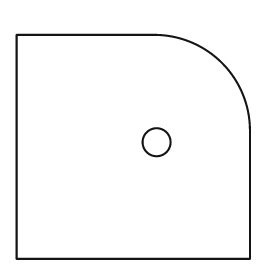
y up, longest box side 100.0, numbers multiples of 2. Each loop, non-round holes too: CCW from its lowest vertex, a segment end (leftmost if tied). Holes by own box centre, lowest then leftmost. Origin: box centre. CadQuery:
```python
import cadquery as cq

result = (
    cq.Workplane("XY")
    .moveTo(-50.0, -48.0)
    .lineTo(50.0, -48.0)
    .lineTo(50.0, 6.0)
    .threePointArc((38.0, 36.0), (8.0, 48.0))
    .lineTo(-50.0, 48.0)
    .close()
    .moveTo(10.0, 2.0)
    .circle(6.0)
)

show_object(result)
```